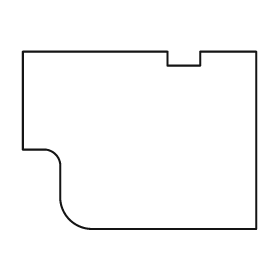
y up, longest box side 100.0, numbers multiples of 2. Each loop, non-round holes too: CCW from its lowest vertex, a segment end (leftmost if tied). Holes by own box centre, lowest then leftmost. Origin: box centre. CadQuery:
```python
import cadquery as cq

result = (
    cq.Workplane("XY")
    .moveTo(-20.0, -38.0)
    .lineTo(50.0, -38.0)
    .lineTo(50.0, 38.0)
    .lineTo(26.0, 38.0)
    .lineTo(26.0, 32.0)
    .lineTo(12.0, 32.0)
    .lineTo(12.0, 38.0)
    .lineTo(-50.0, 38.0)
    .lineTo(-50.0, -4.0)
    .lineTo(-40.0, -4.0)
    .threePointArc((-36.0, -6.0), (-34.0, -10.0))
    .lineTo(-34.0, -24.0)
    .threePointArc((-30.0, -34.0), (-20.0, -38.0))
    .close()
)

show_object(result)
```